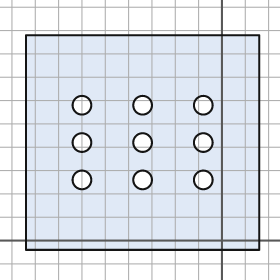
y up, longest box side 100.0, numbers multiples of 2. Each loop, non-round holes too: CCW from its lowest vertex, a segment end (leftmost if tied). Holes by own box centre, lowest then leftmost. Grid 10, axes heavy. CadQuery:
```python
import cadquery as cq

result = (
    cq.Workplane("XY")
    .moveTo(-84.0, -4.0)
    .lineTo(16.0, -4.0)
    .lineTo(16.0, 88.0)
    .lineTo(-84.0, 88.0)
    .close()
    .moveTo(-60.0, 26.0)
    .circle(4.0)
    .moveTo(-34.0, 26.0)
    .circle(4.0)
    .moveTo(-8.0, 26.0)
    .circle(4.0)
    .moveTo(-60.0, 42.0)
    .circle(4.0)
    .moveTo(-34.0, 42.0)
    .circle(4.0)
    .moveTo(-8.0, 42.0)
    .circle(4.0)
    .moveTo(-60.0, 58.0)
    .circle(4.0)
    .moveTo(-34.0, 58.0)
    .circle(4.0)
    .moveTo(-8.0, 58.0)
    .circle(4.0)
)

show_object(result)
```